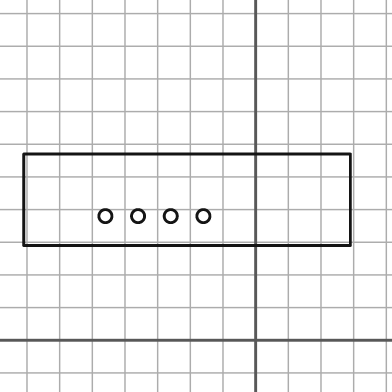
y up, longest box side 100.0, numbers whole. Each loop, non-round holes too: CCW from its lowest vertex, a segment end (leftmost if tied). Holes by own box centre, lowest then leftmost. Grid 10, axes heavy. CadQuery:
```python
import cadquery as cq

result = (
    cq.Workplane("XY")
    .moveTo(-71.0, 29.0)
    .lineTo(29.0, 29.0)
    .lineTo(29.0, 57.0)
    .lineTo(-71.0, 57.0)
    .close()
    .moveTo(-46.0, 38.0)
    .circle(2.0)
    .moveTo(-36.0, 38.0)
    .circle(2.0)
    .moveTo(-26.0, 38.0)
    .circle(2.0)
    .moveTo(-16.0, 38.0)
    .circle(2.0)
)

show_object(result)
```